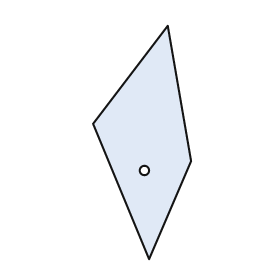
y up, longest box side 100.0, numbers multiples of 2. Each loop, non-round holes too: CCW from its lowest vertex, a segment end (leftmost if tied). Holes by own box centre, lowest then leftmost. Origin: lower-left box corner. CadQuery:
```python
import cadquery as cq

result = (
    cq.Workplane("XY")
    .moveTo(24.0, 0.0)
    .lineTo(42.0, 42.0)
    .lineTo(32.0, 100.0)
    .lineTo(0.0, 58.0)
    .close()
    .moveTo(22.0, 38.0)
    .circle(2.0)
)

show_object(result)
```